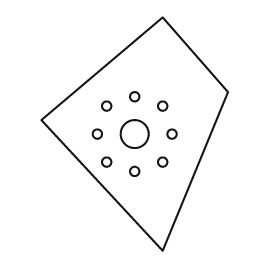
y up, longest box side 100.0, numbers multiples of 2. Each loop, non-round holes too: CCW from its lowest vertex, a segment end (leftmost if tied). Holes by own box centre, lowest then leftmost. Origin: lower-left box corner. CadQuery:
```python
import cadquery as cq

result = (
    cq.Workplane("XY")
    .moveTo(52.0, 0.0)
    .lineTo(80.0, 68.0)
    .lineTo(52.0, 100.0)
    .lineTo(0.0, 56.0)
    .close()
    .moveTo(40.0, 34.0)
    .circle(2.0)
    .moveTo(28.0, 38.0)
    .circle(2.0)
    .moveTo(52.0, 38.0)
    .circle(2.0)
    .moveTo(24.0, 50.0)
    .circle(2.0)
    .moveTo(40.0, 50.0)
    .circle(6.0)
    .moveTo(56.0, 50.0)
    .circle(2.0)
    .moveTo(28.0, 62.0)
    .circle(2.0)
    .moveTo(52.0, 62.0)
    .circle(2.0)
    .moveTo(40.0, 66.0)
    .circle(2.0)
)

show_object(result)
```